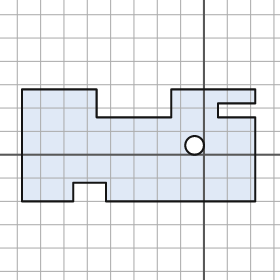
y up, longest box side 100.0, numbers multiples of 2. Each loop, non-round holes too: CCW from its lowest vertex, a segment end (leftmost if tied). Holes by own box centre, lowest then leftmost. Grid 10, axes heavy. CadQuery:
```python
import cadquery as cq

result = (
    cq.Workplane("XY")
    .moveTo(-78.0, -20.0)
    .lineTo(-56.0, -20.0)
    .lineTo(-56.0, -12.0)
    .lineTo(-42.0, -12.0)
    .lineTo(-42.0, -20.0)
    .lineTo(22.0, -20.0)
    .lineTo(22.0, 16.0)
    .lineTo(6.0, 16.0)
    .lineTo(6.0, 22.0)
    .lineTo(22.0, 22.0)
    .lineTo(22.0, 28.0)
    .lineTo(-14.0, 28.0)
    .lineTo(-14.0, 16.0)
    .lineTo(-46.0, 16.0)
    .lineTo(-46.0, 28.0)
    .lineTo(-78.0, 28.0)
    .close()
    .moveTo(-4.0, 4.0)
    .circle(4.0)
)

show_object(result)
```